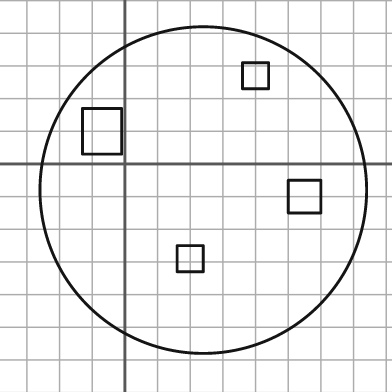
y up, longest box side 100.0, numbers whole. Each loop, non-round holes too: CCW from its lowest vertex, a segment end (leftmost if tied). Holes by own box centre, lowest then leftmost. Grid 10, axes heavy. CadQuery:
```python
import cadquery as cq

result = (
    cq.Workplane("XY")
    .moveTo(24.0, -8.0)
    .circle(50.0)
    .moveTo(16.0, -33.0)
    .lineTo(24.0, -33.0)
    .lineTo(24.0, -25.0)
    .lineTo(16.0, -25.0)
    .close()
    .moveTo(50.0, -15.0)
    .lineTo(60.0, -15.0)
    .lineTo(60.0, -5.0)
    .lineTo(50.0, -5.0)
    .close()
    .moveTo(-13.0, 3.0)
    .lineTo(-1.0, 3.0)
    .lineTo(-1.0, 17.0)
    .lineTo(-13.0, 17.0)
    .close()
    .moveTo(36.0, 23.0)
    .lineTo(44.0, 23.0)
    .lineTo(44.0, 31.0)
    .lineTo(36.0, 31.0)
    .close()
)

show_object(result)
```